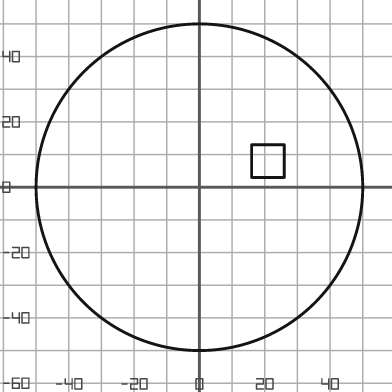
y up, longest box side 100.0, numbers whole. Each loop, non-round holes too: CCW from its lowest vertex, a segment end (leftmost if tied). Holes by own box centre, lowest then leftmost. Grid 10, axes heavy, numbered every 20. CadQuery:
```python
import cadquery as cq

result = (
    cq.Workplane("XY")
    .moveTo(0.0, 0.0)
    .circle(50.0)
    .moveTo(16.0, 3.0)
    .lineTo(26.0, 3.0)
    .lineTo(26.0, 13.0)
    .lineTo(16.0, 13.0)
    .close()
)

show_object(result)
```